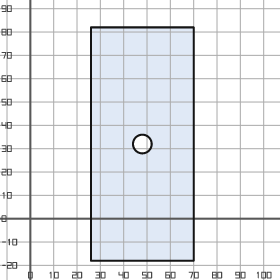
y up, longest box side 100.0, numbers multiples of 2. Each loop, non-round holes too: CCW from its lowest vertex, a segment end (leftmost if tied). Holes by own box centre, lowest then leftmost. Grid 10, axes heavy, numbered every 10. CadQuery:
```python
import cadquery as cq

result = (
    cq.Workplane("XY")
    .moveTo(26.0, -18.0)
    .lineTo(70.0, -18.0)
    .lineTo(70.0, 82.0)
    .lineTo(26.0, 82.0)
    .close()
    .moveTo(48.0, 32.0)
    .circle(4.0)
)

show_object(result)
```